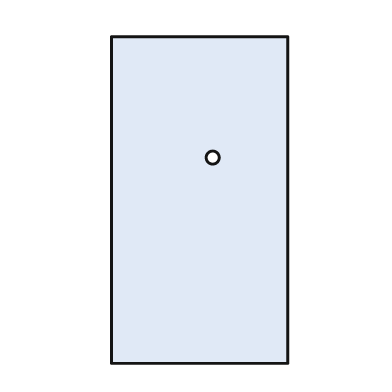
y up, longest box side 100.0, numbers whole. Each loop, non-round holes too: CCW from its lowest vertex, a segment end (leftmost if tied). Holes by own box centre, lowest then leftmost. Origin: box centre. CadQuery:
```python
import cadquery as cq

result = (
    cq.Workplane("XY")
    .moveTo(-27.0, -50.0)
    .lineTo(27.0, -50.0)
    .lineTo(27.0, 50.0)
    .lineTo(-27.0, 50.0)
    .close()
    .moveTo(4.0, 13.0)
    .circle(2.0)
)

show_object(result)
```